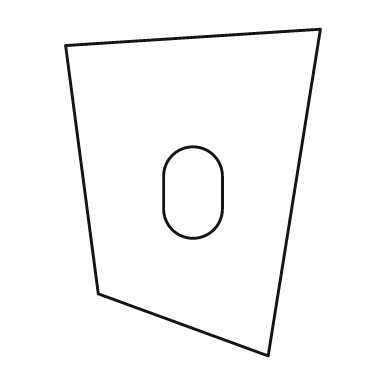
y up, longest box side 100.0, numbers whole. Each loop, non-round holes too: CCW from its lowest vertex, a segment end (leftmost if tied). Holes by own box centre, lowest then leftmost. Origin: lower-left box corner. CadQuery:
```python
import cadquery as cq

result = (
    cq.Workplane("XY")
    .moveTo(62.0, 0.0)
    .lineTo(78.0, 100.0)
    .lineTo(0.0, 95.0)
    .lineTo(10.0, 19.0)
    .close()
    .moveTo(30.0, 45.0)
    .threePointArc((39.0, 36.0), (48.0, 45.0))
    .lineTo(48.0, 55.0)
    .threePointArc((39.0, 64.0), (30.0, 55.0))
    .close()
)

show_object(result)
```